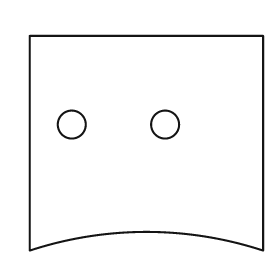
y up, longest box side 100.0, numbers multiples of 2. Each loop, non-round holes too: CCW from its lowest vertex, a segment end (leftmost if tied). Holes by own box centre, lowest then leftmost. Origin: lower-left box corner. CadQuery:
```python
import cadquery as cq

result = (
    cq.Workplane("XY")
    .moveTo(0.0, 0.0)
    .threePointArc((50.0, 8.0), (100.0, 0.0))
    .lineTo(100.0, 92.0)
    .lineTo(0.0, 92.0)
    .close()
    .moveTo(18.0, 54.0)
    .circle(6.0)
    .moveTo(58.0, 54.0)
    .circle(6.0)
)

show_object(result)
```